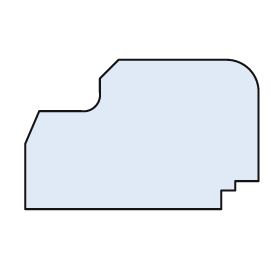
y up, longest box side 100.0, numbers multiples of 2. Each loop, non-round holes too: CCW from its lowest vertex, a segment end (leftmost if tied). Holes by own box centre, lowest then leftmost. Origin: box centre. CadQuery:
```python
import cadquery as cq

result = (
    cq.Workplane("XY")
    .moveTo(-50.0, -32.0)
    .lineTo(34.0, -32.0)
    .lineTo(34.0, -24.0)
    .lineTo(40.0, -24.0)
    .lineTo(40.0, -20.0)
    .lineTo(50.0, -20.0)
    .lineTo(50.0, 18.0)
    .threePointArc((46.0, 28.0), (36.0, 32.0))
    .lineTo(-10.0, 32.0)
    .lineTo(-18.0, 24.0)
    .lineTo(-18.0, 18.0)
    .threePointArc((-20.0, 12.0), (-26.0, 10.0))
    .lineTo(-44.0, 10.0)
    .lineTo(-50.0, -4.0)
    .close()
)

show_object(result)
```